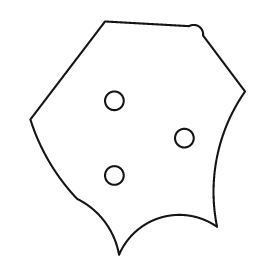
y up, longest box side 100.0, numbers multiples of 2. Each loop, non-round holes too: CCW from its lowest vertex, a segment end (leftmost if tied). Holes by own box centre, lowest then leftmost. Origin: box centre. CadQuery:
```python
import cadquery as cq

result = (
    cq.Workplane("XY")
    .moveTo(-8.0, -50.0)
    .threePointArc((10.0, -34.0), (34.0, -38.0))
    .threePointArc((34.0, -8.0), (46.0, 20.0))
    .lineTo(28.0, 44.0)
    .threePointArc((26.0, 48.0), (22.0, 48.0))
    .lineTo(-14.0, 50.0)
    .lineTo(-46.0, 8.0)
    .threePointArc((-38.0, -10.0), (-26.0, -26.0))
    .threePointArc((-14.0, -36.0), (-8.0, -50.0))
    .close()
    .moveTo(-10.0, -16.0)
    .circle(4.0)
    .moveTo(20.0, 0.0)
    .circle(4.0)
    .moveTo(-10.0, 16.0)
    .circle(4.0)
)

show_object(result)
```